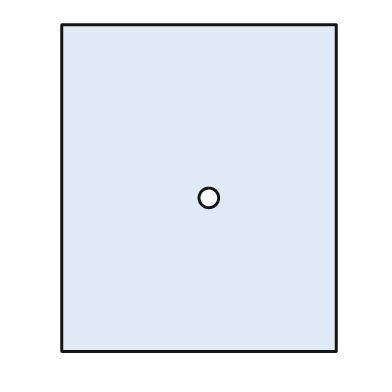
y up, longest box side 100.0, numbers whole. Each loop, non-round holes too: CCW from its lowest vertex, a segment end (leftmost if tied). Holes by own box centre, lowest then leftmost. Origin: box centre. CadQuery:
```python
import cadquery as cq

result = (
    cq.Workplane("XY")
    .moveTo(-42.0, -50.0)
    .lineTo(42.0, -50.0)
    .lineTo(42.0, 50.0)
    .lineTo(-42.0, 50.0)
    .close()
    .moveTo(3.0, -3.0)
    .circle(3.0)
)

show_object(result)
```